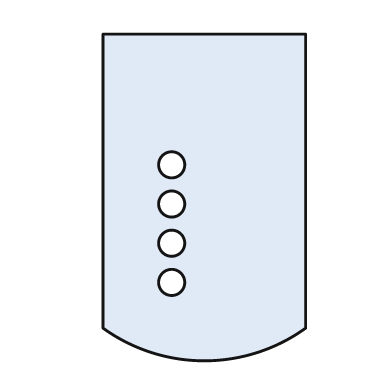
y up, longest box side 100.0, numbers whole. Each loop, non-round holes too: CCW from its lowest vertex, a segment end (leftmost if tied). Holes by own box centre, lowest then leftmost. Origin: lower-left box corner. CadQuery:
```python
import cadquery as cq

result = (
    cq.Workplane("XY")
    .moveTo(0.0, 10.0)
    .threePointArc((31.0, 0.0), (62.0, 10.0))
    .lineTo(62.0, 100.0)
    .lineTo(0.0, 100.0)
    .close()
    .moveTo(21.0, 24.0)
    .circle(4.0)
    .moveTo(21.0, 36.0)
    .circle(4.0)
    .moveTo(21.0, 48.0)
    .circle(4.0)
    .moveTo(21.0, 60.0)
    .circle(4.0)
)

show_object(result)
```